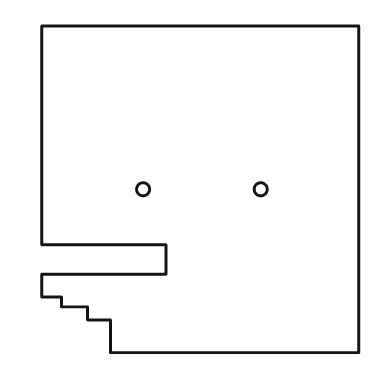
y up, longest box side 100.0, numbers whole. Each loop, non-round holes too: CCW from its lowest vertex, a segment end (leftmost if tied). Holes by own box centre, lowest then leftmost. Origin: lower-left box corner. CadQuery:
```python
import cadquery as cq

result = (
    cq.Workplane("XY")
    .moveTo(21.0, 0.0)
    .lineTo(97.0, 0.0)
    .lineTo(97.0, 100.0)
    .lineTo(0.0, 100.0)
    .lineTo(0.0, 33.0)
    .lineTo(38.0, 33.0)
    .lineTo(38.0, 24.0)
    .lineTo(0.0, 24.0)
    .lineTo(0.0, 17.0)
    .lineTo(6.0, 17.0)
    .lineTo(6.0, 14.0)
    .lineTo(14.0, 14.0)
    .lineTo(14.0, 10.0)
    .lineTo(21.0, 10.0)
    .close()
    .moveTo(31.0, 50.0)
    .circle(2.0)
    .moveTo(67.0, 50.0)
    .circle(2.0)
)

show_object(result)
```